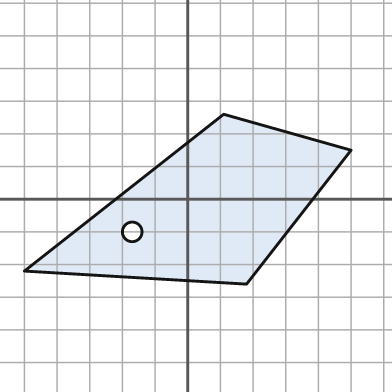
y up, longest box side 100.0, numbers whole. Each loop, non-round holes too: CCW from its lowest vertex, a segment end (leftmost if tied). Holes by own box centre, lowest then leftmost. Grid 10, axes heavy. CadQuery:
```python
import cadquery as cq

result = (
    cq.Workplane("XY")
    .moveTo(18.0, -26.0)
    .lineTo(50.0, 15.0)
    .lineTo(11.0, 26.0)
    .lineTo(-50.0, -22.0)
    .close()
    .moveTo(-17.0, -10.0)
    .circle(3.0)
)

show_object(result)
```